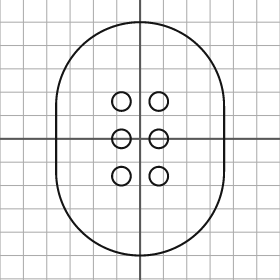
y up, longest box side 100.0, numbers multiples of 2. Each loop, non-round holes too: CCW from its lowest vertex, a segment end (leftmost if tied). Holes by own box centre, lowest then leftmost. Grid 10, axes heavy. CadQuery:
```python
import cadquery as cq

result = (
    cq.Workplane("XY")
    .moveTo(-36.0, -14.0)
    .threePointArc((0.0, -50.0), (36.0, -14.0))
    .lineTo(36.0, 14.0)
    .threePointArc((0.0, 50.0), (-36.0, 14.0))
    .close()
    .moveTo(-8.0, -16.0)
    .circle(4.0)
    .moveTo(8.0, -16.0)
    .circle(4.0)
    .moveTo(-8.0, 0.0)
    .circle(4.0)
    .moveTo(8.0, 0.0)
    .circle(4.0)
    .moveTo(-8.0, 16.0)
    .circle(4.0)
    .moveTo(8.0, 16.0)
    .circle(4.0)
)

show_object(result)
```